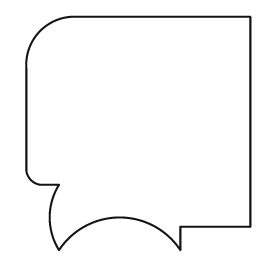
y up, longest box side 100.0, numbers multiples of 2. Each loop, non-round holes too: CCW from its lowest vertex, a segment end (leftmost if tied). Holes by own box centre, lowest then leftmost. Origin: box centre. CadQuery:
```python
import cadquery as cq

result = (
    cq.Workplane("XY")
    .moveTo(-34.0, -50.0)
    .threePointArc((-8.0, -36.0), (18.0, -50.0))
    .lineTo(18.0, -40.0)
    .lineTo(48.0, -40.0)
    .lineTo(48.0, 50.0)
    .lineTo(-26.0, 50.0)
    .threePointArc((-42.0, 44.0), (-48.0, 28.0))
    .lineTo(-48.0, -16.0)
    .threePointArc((-46.0, -20.0), (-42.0, -22.0))
    .lineTo(-34.0, -22.0)
    .threePointArc((-38.0, -36.0), (-34.0, -50.0))
    .close()
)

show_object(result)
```